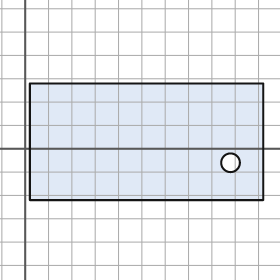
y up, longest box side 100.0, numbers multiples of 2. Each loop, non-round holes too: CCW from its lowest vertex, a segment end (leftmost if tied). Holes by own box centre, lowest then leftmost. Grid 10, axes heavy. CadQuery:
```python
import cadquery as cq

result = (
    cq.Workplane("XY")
    .moveTo(2.0, -22.0)
    .lineTo(102.0, -22.0)
    .lineTo(102.0, 28.0)
    .lineTo(2.0, 28.0)
    .close()
    .moveTo(88.0, -6.0)
    .circle(4.0)
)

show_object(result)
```